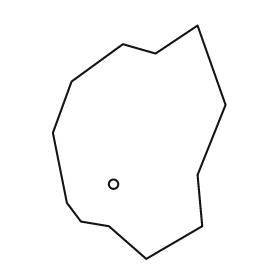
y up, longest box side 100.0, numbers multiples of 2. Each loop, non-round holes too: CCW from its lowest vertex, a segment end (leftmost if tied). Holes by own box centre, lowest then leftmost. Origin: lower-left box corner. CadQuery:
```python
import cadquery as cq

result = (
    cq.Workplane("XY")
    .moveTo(40.0, 0.0)
    .lineTo(64.0, 14.0)
    .lineTo(62.0, 36.0)
    .lineTo(74.0, 66.0)
    .lineTo(62.0, 100.0)
    .lineTo(44.0, 88.0)
    .lineTo(30.0, 92.0)
    .lineTo(8.0, 76.0)
    .lineTo(0.0, 54.0)
    .lineTo(6.0, 24.0)
    .lineTo(12.0, 16.0)
    .lineTo(24.0, 14.0)
    .close()
    .moveTo(26.0, 32.0)
    .circle(2.0)
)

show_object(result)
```